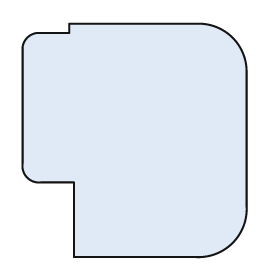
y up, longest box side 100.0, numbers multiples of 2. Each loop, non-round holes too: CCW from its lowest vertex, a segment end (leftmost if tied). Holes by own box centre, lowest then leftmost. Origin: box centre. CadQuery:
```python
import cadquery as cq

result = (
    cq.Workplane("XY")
    .moveTo(-26.0, -50.0)
    .lineTo(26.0, -50.0)
    .threePointArc((42.0, -44.0), (48.0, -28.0))
    .lineTo(48.0, 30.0)
    .threePointArc((42.0, 44.0), (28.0, 50.0))
    .lineTo(-28.0, 50.0)
    .lineTo(-28.0, 46.0)
    .lineTo(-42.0, 46.0)
    .threePointArc((-46.0, 44.0), (-48.0, 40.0))
    .lineTo(-48.0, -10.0)
    .threePointArc((-46.0, -16.0), (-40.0, -18.0))
    .lineTo(-26.0, -18.0)
    .close()
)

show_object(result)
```